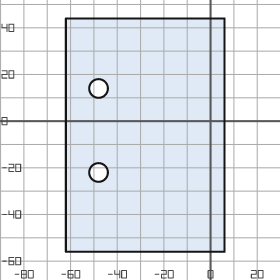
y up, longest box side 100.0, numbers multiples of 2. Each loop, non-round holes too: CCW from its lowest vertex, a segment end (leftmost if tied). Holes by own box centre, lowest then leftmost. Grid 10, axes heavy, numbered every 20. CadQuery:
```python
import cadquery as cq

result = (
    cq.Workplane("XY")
    .moveTo(-62.0, -56.0)
    .lineTo(6.0, -56.0)
    .lineTo(6.0, 44.0)
    .lineTo(-62.0, 44.0)
    .close()
    .moveTo(-48.0, -22.0)
    .circle(4.0)
    .moveTo(-48.0, 14.0)
    .circle(4.0)
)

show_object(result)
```